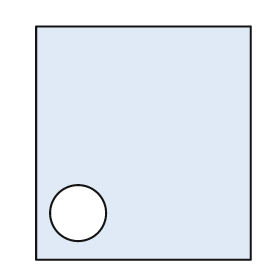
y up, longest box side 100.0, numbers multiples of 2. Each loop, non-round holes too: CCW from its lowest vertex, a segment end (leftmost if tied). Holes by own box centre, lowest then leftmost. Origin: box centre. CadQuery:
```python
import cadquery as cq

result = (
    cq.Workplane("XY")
    .moveTo(-46.0, -50.0)
    .lineTo(46.0, -50.0)
    .lineTo(46.0, 50.0)
    .lineTo(-46.0, 50.0)
    .close()
    .moveTo(-28.0, -30.0)
    .circle(12.0)
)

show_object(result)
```